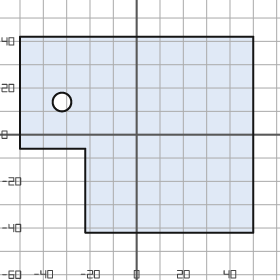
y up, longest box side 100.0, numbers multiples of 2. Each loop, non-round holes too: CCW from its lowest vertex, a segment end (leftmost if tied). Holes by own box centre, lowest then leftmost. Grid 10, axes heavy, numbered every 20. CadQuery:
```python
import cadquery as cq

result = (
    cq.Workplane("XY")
    .moveTo(-22.0, -42.0)
    .lineTo(50.0, -42.0)
    .lineTo(50.0, 42.0)
    .lineTo(-50.0, 42.0)
    .lineTo(-50.0, -6.0)
    .lineTo(-22.0, -6.0)
    .close()
    .moveTo(-32.0, 14.0)
    .circle(4.0)
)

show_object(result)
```